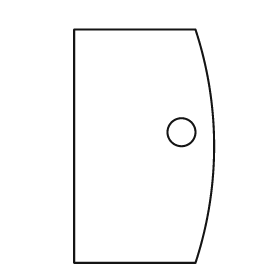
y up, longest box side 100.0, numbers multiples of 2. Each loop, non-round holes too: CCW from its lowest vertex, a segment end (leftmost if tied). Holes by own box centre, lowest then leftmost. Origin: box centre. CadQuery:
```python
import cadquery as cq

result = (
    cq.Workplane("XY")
    .moveTo(-30.0, -50.0)
    .lineTo(22.0, -50.0)
    .threePointArc((30.0, 0.0), (22.0, 50.0))
    .lineTo(-30.0, 50.0)
    .close()
    .moveTo(16.0, 6.0)
    .circle(6.0)
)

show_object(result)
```